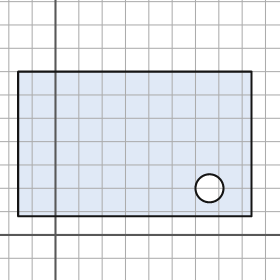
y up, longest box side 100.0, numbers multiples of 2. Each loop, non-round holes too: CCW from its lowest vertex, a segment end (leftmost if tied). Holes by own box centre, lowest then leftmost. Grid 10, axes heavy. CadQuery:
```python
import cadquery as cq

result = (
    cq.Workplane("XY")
    .moveTo(-16.0, 8.0)
    .lineTo(84.0, 8.0)
    .lineTo(84.0, 70.0)
    .lineTo(-16.0, 70.0)
    .close()
    .moveTo(66.0, 20.0)
    .circle(6.0)
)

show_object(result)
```